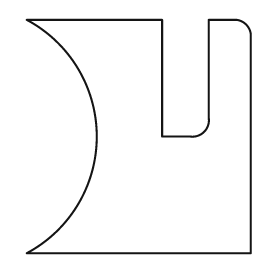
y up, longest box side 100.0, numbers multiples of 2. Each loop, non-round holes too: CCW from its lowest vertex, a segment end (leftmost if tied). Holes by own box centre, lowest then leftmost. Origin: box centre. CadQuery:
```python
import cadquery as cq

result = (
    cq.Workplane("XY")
    .moveTo(-48.0, -50.0)
    .lineTo(48.0, -50.0)
    .lineTo(48.0, 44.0)
    .threePointArc((46.0, 48.0), (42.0, 50.0))
    .lineTo(30.0, 50.0)
    .lineTo(30.0, 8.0)
    .threePointArc((28.0, 2.0), (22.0, 0.0))
    .lineTo(10.0, 0.0)
    .lineTo(10.0, 50.0)
    .lineTo(-48.0, 50.0)
    .threePointArc((-18.0, 0.0), (-48.0, -50.0))
    .close()
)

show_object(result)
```